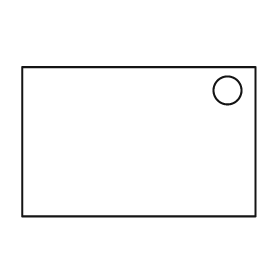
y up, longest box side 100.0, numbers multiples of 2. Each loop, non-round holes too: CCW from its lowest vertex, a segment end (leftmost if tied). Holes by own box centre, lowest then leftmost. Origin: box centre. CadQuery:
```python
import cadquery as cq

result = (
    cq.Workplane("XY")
    .moveTo(-50.0, -32.0)
    .lineTo(50.0, -32.0)
    .lineTo(50.0, 32.0)
    .lineTo(-50.0, 32.0)
    .close()
    .moveTo(38.0, 22.0)
    .circle(6.0)
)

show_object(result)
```